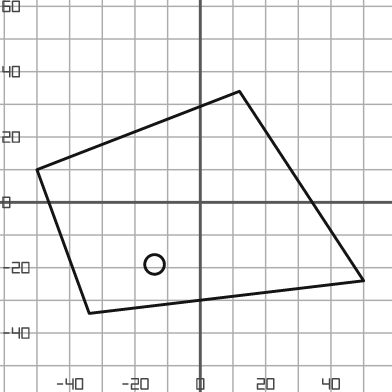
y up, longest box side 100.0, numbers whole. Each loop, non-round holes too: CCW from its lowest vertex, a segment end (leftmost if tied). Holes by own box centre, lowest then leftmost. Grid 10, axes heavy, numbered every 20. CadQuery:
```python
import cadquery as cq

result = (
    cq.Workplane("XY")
    .moveTo(-34.0, -34.0)
    .lineTo(50.0, -24.0)
    .lineTo(12.0, 34.0)
    .lineTo(-50.0, 10.0)
    .close()
    .moveTo(-14.0, -19.0)
    .circle(3.0)
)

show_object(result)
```